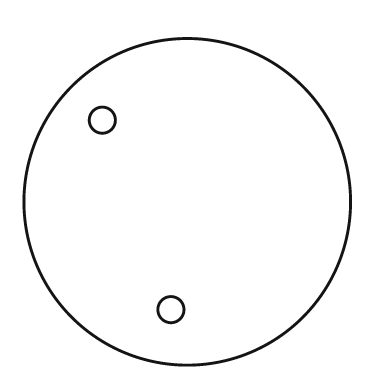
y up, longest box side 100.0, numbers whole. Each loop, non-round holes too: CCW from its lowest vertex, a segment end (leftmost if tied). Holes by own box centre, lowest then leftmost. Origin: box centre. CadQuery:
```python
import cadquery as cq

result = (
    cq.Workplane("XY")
    .moveTo(0.0, 0.0)
    .circle(50.0)
    .moveTo(-5.0, -33.0)
    .circle(4.0)
    .moveTo(-26.0, 25.0)
    .circle(4.0)
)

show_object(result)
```